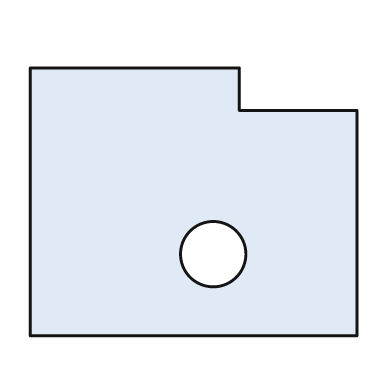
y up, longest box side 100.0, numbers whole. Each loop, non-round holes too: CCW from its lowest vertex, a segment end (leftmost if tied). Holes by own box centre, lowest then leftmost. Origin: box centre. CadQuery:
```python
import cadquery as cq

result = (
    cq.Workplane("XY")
    .moveTo(-50.0, -41.0)
    .lineTo(50.0, -41.0)
    .lineTo(50.0, 28.0)
    .lineTo(14.0, 28.0)
    .lineTo(14.0, 41.0)
    .lineTo(-50.0, 41.0)
    .close()
    .moveTo(6.0, -16.0)
    .circle(10.0)
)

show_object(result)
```